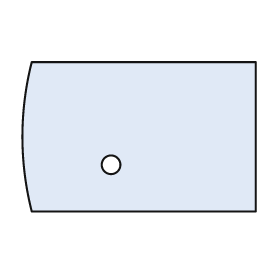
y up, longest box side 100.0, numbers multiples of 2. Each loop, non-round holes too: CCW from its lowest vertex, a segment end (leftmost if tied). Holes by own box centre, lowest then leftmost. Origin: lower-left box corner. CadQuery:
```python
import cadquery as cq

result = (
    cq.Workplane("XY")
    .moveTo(4.0, 0.0)
    .lineTo(100.0, 0.0)
    .lineTo(100.0, 64.0)
    .lineTo(4.0, 64.0)
    .threePointArc((0.0, 32.0), (4.0, 0.0))
    .close()
    .moveTo(38.0, 20.0)
    .circle(4.0)
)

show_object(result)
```